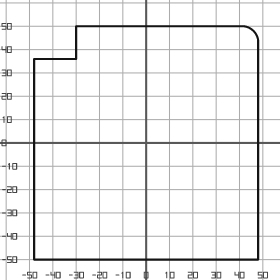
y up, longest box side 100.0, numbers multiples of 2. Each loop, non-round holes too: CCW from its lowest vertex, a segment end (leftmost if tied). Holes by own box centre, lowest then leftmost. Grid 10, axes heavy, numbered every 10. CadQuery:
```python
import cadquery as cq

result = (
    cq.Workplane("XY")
    .moveTo(-48.0, -50.0)
    .lineTo(48.0, -50.0)
    .lineTo(48.0, 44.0)
    .threePointArc((46.0, 48.0), (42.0, 50.0))
    .lineTo(-30.0, 50.0)
    .lineTo(-30.0, 36.0)
    .lineTo(-48.0, 36.0)
    .close()
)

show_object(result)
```